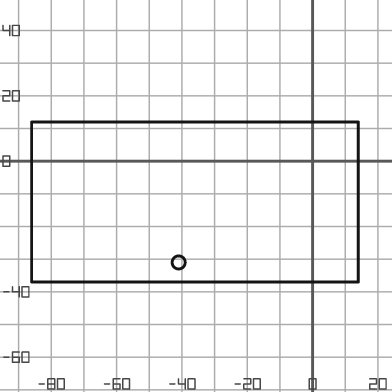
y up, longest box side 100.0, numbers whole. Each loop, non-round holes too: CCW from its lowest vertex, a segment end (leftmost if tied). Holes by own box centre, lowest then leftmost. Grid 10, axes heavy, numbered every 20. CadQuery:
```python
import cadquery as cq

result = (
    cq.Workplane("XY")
    .moveTo(-86.0, -37.0)
    .lineTo(14.0, -37.0)
    .lineTo(14.0, 12.0)
    .lineTo(-86.0, 12.0)
    .close()
    .moveTo(-41.0, -31.0)
    .circle(2.0)
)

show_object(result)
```